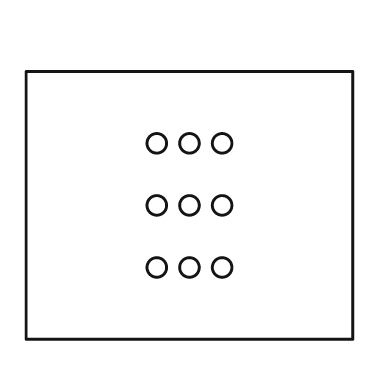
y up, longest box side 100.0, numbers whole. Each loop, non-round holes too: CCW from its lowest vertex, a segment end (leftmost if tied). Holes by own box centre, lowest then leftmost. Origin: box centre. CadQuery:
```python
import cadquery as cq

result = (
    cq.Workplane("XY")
    .moveTo(-50.0, -41.0)
    .lineTo(50.0, -41.0)
    .lineTo(50.0, 41.0)
    .lineTo(-50.0, 41.0)
    .close()
    .moveTo(-10.0, -19.0)
    .circle(3.0)
    .moveTo(0.0, -19.0)
    .circle(3.0)
    .moveTo(10.0, -19.0)
    .circle(3.0)
    .moveTo(-10.0, 0.0)
    .circle(3.0)
    .moveTo(0.0, 0.0)
    .circle(3.0)
    .moveTo(10.0, 0.0)
    .circle(3.0)
    .moveTo(-10.0, 19.0)
    .circle(3.0)
    .moveTo(0.0, 19.0)
    .circle(3.0)
    .moveTo(10.0, 19.0)
    .circle(3.0)
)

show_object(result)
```